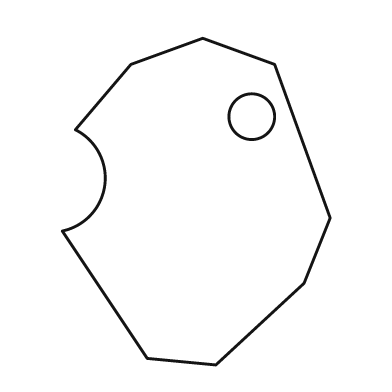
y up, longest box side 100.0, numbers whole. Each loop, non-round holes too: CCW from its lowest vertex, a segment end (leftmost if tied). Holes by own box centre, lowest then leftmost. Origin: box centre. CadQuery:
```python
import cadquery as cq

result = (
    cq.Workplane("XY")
    .moveTo(6.0, -50.0)
    .lineTo(33.0, -25.0)
    .lineTo(41.0, -5.0)
    .lineTo(24.0, 42.0)
    .lineTo(2.0, 50.0)
    .lineTo(-20.0, 42.0)
    .lineTo(-37.0, 22.0)
    .threePointArc((-28.0, 5.0), (-41.0, -9.0))
    .lineTo(-15.0, -48.0)
    .close()
    .moveTo(17.0, 26.0)
    .circle(7.0)
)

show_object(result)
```